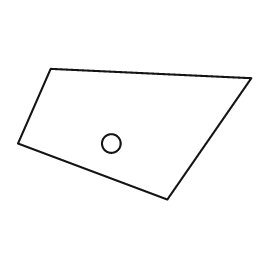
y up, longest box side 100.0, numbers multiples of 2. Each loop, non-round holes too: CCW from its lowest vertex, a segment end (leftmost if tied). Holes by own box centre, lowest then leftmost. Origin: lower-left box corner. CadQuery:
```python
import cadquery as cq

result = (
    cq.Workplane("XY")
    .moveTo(64.0, 0.0)
    .lineTo(100.0, 52.0)
    .lineTo(14.0, 56.0)
    .lineTo(0.0, 24.0)
    .close()
    .moveTo(40.0, 24.0)
    .circle(4.0)
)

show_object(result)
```